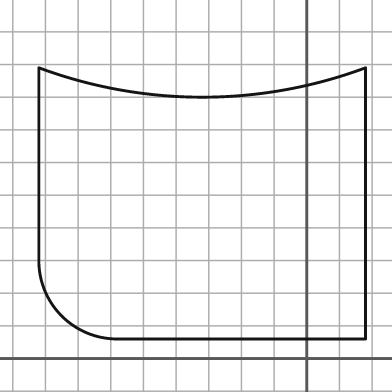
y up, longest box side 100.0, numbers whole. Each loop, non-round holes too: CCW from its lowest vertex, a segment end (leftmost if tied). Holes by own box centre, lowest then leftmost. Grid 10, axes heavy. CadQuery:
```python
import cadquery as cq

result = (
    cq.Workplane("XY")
    .moveTo(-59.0, 6.0)
    .lineTo(18.0, 6.0)
    .lineTo(18.0, 89.0)
    .threePointArc((-32.0, 80.0), (-82.0, 89.0))
    .lineTo(-82.0, 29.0)
    .threePointArc((-75.0, 13.0), (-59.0, 6.0))
    .close()
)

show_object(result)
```